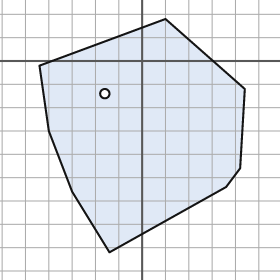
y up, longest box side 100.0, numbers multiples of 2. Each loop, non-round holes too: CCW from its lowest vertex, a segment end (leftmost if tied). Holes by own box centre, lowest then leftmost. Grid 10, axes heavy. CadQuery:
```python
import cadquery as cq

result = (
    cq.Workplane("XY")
    .moveTo(-14.0, -82.0)
    .lineTo(36.0, -54.0)
    .lineTo(42.0, -46.0)
    .lineTo(44.0, -12.0)
    .lineTo(10.0, 18.0)
    .lineTo(-44.0, -2.0)
    .lineTo(-40.0, -30.0)
    .lineTo(-30.0, -56.0)
    .close()
    .moveTo(-16.0, -14.0)
    .circle(2.0)
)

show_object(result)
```